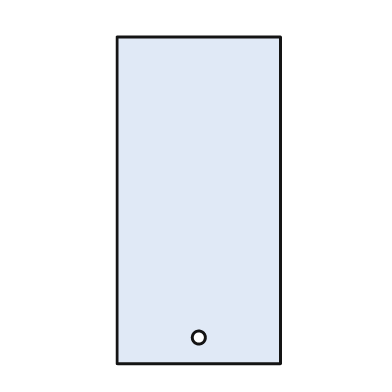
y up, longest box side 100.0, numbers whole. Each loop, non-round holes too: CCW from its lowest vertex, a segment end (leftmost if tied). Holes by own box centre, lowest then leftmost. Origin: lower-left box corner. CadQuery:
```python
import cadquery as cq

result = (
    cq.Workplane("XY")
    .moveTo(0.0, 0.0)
    .lineTo(50.0, 0.0)
    .lineTo(50.0, 100.0)
    .lineTo(0.0, 100.0)
    .close()
    .moveTo(25.0, 8.0)
    .circle(2.0)
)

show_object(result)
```